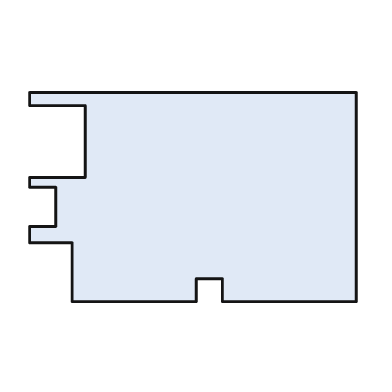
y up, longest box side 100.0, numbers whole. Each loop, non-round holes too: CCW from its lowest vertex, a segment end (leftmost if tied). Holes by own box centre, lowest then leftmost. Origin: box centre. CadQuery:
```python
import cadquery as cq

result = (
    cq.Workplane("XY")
    .moveTo(-37.0, -32.0)
    .lineTo(1.0, -32.0)
    .lineTo(1.0, -25.0)
    .lineTo(9.0, -25.0)
    .lineTo(9.0, -32.0)
    .lineTo(50.0, -32.0)
    .lineTo(50.0, 32.0)
    .lineTo(-50.0, 32.0)
    .lineTo(-50.0, 28.0)
    .lineTo(-33.0, 28.0)
    .lineTo(-33.0, 6.0)
    .lineTo(-50.0, 6.0)
    .lineTo(-50.0, 3.0)
    .lineTo(-42.0, 3.0)
    .lineTo(-42.0, -9.0)
    .lineTo(-50.0, -9.0)
    .lineTo(-50.0, -14.0)
    .lineTo(-37.0, -14.0)
    .close()
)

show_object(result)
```